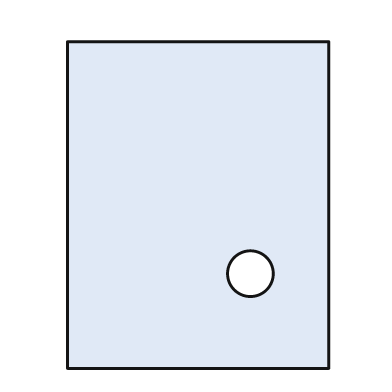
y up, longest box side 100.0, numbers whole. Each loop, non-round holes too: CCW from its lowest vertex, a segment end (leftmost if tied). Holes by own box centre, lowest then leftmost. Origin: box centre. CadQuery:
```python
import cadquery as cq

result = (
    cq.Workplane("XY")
    .moveTo(-40.0, -50.0)
    .lineTo(40.0, -50.0)
    .lineTo(40.0, 50.0)
    .lineTo(-40.0, 50.0)
    .close()
    .moveTo(16.0, -21.0)
    .circle(7.0)
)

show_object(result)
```